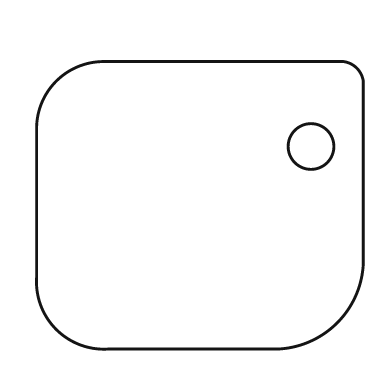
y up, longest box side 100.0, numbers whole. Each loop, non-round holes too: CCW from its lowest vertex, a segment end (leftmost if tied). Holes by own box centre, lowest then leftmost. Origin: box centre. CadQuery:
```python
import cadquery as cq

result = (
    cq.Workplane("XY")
    .moveTo(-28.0, -44.0)
    .lineTo(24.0, -44.0)
    .threePointArc((42.0, -36.0), (50.0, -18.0))
    .lineTo(50.0, 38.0)
    .threePointArc((48.0, 42.0), (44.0, 44.0))
    .lineTo(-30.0, 44.0)
    .threePointArc((-44.0, 38.0), (-50.0, 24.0))
    .lineTo(-50.0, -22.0)
    .threePointArc((-44.0, -38.0), (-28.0, -44.0))
    .close()
    .moveTo(34.0, 18.0)
    .circle(7.0)
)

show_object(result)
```